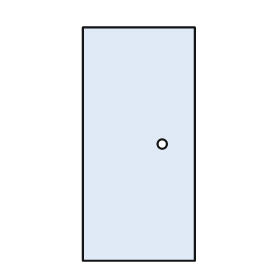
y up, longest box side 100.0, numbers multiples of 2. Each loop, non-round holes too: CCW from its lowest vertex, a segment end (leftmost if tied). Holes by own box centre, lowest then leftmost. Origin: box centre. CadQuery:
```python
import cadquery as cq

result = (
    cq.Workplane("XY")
    .moveTo(-24.0, -50.0)
    .lineTo(24.0, -50.0)
    .lineTo(24.0, 50.0)
    .lineTo(-24.0, 50.0)
    .close()
    .moveTo(10.0, 0.0)
    .circle(2.0)
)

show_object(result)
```